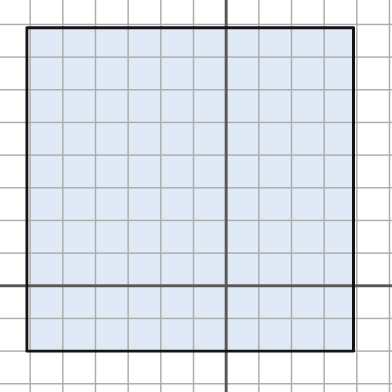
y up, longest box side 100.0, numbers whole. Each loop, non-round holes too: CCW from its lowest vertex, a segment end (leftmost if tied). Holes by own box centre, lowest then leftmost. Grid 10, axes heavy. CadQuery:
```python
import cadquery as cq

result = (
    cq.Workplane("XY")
    .moveTo(-61.0, -20.0)
    .lineTo(39.0, -20.0)
    .lineTo(39.0, 79.0)
    .lineTo(-61.0, 79.0)
    .close()
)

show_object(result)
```